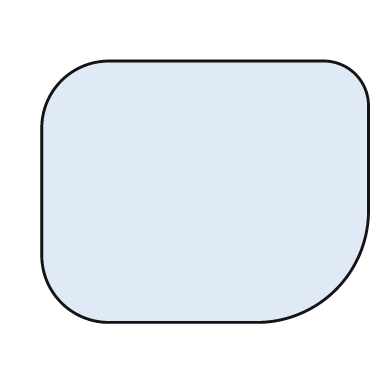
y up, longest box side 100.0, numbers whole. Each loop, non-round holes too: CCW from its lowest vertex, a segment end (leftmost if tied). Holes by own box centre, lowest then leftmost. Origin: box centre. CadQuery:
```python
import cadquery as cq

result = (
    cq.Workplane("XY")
    .moveTo(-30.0, -40.0)
    .lineTo(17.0, -40.0)
    .threePointArc((40.0, -30.0), (50.0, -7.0))
    .lineTo(50.0, 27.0)
    .threePointArc((46.0, 36.0), (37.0, 40.0))
    .lineTo(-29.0, 40.0)
    .threePointArc((-44.0, 34.0), (-50.0, 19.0))
    .lineTo(-50.0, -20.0)
    .threePointArc((-44.0, -34.0), (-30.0, -40.0))
    .close()
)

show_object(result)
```